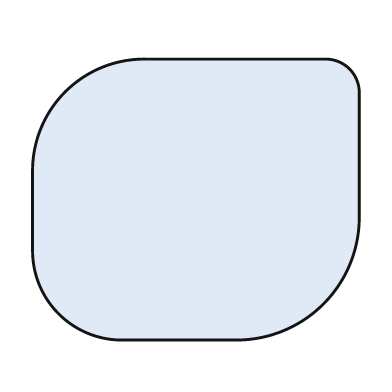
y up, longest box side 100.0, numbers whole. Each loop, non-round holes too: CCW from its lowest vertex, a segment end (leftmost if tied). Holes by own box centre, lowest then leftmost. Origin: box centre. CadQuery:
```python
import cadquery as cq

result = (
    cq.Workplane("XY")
    .moveTo(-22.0, -43.0)
    .lineTo(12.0, -43.0)
    .threePointArc((39.0, -32.0), (50.0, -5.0))
    .lineTo(50.0, 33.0)
    .threePointArc((47.0, 40.0), (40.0, 43.0))
    .lineTo(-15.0, 43.0)
    .threePointArc((-40.0, 33.0), (-50.0, 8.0))
    .lineTo(-50.0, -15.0)
    .threePointArc((-42.0, -35.0), (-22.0, -43.0))
    .close()
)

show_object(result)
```